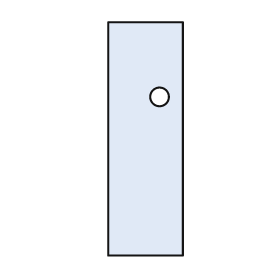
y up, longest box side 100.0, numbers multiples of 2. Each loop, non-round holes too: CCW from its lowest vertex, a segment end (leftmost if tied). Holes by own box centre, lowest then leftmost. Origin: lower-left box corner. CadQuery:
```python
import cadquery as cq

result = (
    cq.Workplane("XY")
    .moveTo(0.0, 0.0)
    .lineTo(32.0, 0.0)
    .lineTo(32.0, 100.0)
    .lineTo(0.0, 100.0)
    .close()
    .moveTo(22.0, 68.0)
    .circle(4.0)
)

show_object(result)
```